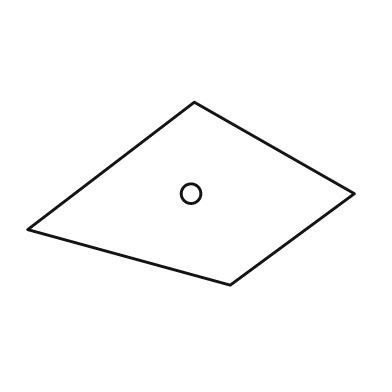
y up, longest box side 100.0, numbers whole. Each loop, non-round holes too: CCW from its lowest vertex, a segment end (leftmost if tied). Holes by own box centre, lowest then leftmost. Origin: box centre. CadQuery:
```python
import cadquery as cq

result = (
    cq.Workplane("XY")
    .moveTo(12.0, -28.0)
    .lineTo(50.0, 0.0)
    .lineTo(1.0, 28.0)
    .lineTo(-50.0, -11.0)
    .close()
    .moveTo(0.0, 0.0)
    .circle(3.0)
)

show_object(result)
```